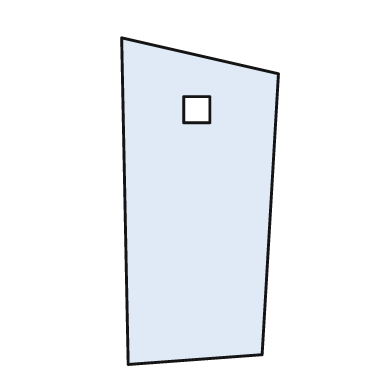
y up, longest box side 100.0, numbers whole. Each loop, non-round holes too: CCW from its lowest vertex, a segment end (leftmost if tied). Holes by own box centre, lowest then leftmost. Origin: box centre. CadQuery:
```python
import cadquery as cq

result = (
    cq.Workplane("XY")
    .moveTo(-22.0, -50.0)
    .lineTo(19.0, -47.0)
    .lineTo(24.0, 39.0)
    .lineTo(-24.0, 50.0)
    .close()
    .moveTo(-5.0, 24.0)
    .lineTo(3.0, 24.0)
    .lineTo(3.0, 32.0)
    .lineTo(-5.0, 32.0)
    .close()
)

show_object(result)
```